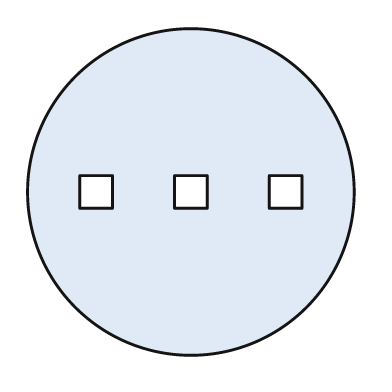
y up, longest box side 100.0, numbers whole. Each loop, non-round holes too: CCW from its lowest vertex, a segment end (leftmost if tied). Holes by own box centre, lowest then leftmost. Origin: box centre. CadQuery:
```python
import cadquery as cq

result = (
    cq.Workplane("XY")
    .moveTo(0.0, 0.0)
    .circle(50.0)
    .moveTo(-34.0, -5.0)
    .lineTo(-24.0, -5.0)
    .lineTo(-24.0, 5.0)
    .lineTo(-34.0, 5.0)
    .close()
    .moveTo(-5.0, -5.0)
    .lineTo(5.0, -5.0)
    .lineTo(5.0, 5.0)
    .lineTo(-5.0, 5.0)
    .close()
    .moveTo(24.0, -5.0)
    .lineTo(34.0, -5.0)
    .lineTo(34.0, 5.0)
    .lineTo(24.0, 5.0)
    .close()
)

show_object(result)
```